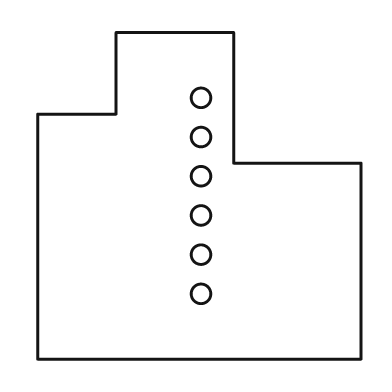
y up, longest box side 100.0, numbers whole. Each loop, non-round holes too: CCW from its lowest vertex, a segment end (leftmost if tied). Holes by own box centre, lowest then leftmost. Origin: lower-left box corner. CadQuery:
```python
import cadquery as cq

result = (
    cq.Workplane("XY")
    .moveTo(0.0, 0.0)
    .lineTo(99.0, 0.0)
    .lineTo(99.0, 60.0)
    .lineTo(60.0, 60.0)
    .lineTo(60.0, 100.0)
    .lineTo(24.0, 100.0)
    .lineTo(24.0, 75.0)
    .lineTo(0.0, 75.0)
    .close()
    .moveTo(50.0, 20.0)
    .circle(3.0)
    .moveTo(50.0, 32.0)
    .circle(3.0)
    .moveTo(50.0, 44.0)
    .circle(3.0)
    .moveTo(50.0, 56.0)
    .circle(3.0)
    .moveTo(50.0, 68.0)
    .circle(3.0)
    .moveTo(50.0, 80.0)
    .circle(3.0)
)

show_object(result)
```